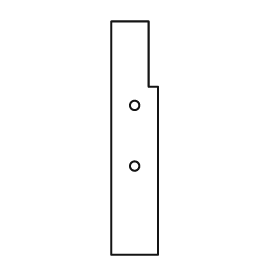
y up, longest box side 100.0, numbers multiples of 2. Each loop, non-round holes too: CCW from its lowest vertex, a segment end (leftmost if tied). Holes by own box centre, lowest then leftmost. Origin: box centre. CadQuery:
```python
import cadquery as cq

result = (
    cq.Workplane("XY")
    .moveTo(-10.0, -50.0)
    .lineTo(10.0, -50.0)
    .lineTo(10.0, 22.0)
    .lineTo(6.0, 22.0)
    .lineTo(6.0, 50.0)
    .lineTo(-10.0, 50.0)
    .close()
    .moveTo(0.0, -12.0)
    .circle(2.0)
    .moveTo(0.0, 14.0)
    .circle(2.0)
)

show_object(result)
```